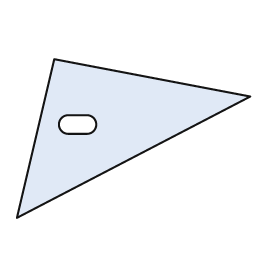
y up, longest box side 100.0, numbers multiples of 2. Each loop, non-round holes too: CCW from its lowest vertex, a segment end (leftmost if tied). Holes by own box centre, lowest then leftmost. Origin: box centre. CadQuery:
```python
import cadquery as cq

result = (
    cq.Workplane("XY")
    .moveTo(-50.0, -34.0)
    .lineTo(50.0, 18.0)
    .lineTo(-34.0, 34.0)
    .close()
    .moveTo(-28.0, 2.0)
    .lineTo(-20.0, 2.0)
    .threePointArc((-16.0, 6.0), (-20.0, 10.0))
    .lineTo(-28.0, 10.0)
    .threePointArc((-32.0, 6.0), (-28.0, 2.0))
    .close()
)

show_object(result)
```